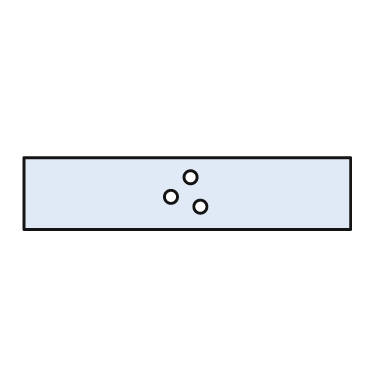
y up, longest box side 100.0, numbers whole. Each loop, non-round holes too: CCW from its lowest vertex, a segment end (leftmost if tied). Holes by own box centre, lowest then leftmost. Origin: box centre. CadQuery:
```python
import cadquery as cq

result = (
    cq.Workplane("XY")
    .moveTo(-50.0, -11.0)
    .lineTo(50.0, -11.0)
    .lineTo(50.0, 11.0)
    .lineTo(-50.0, 11.0)
    .close()
    .moveTo(4.0, -4.0)
    .circle(2.0)
    .moveTo(-5.0, -1.0)
    .circle(2.0)
    .moveTo(1.0, 5.0)
    .circle(2.0)
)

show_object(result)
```